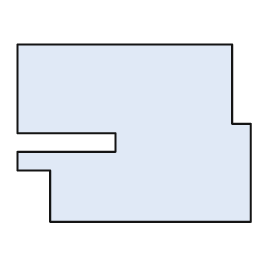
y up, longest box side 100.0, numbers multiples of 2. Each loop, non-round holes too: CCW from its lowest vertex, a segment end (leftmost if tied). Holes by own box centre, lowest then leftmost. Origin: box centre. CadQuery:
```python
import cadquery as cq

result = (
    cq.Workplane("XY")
    .moveTo(-36.0, -38.0)
    .lineTo(50.0, -38.0)
    .lineTo(50.0, 4.0)
    .lineTo(42.0, 4.0)
    .lineTo(42.0, 38.0)
    .lineTo(-50.0, 38.0)
    .lineTo(-50.0, 0.0)
    .lineTo(-8.0, 0.0)
    .lineTo(-8.0, -8.0)
    .lineTo(-50.0, -8.0)
    .lineTo(-50.0, -16.0)
    .lineTo(-36.0, -16.0)
    .close()
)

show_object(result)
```